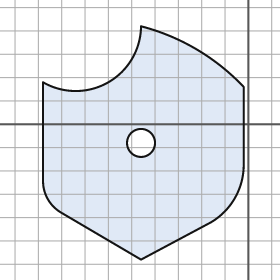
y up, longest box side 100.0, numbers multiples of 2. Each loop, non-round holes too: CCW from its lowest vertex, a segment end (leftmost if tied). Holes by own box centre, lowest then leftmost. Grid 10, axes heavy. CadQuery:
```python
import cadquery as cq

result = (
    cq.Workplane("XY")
    .moveTo(-46.0, -58.0)
    .lineTo(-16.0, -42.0)
    .threePointArc((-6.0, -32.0), (-2.0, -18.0))
    .lineTo(-2.0, 16.0)
    .threePointArc((-22.0, 32.0), (-46.0, 42.0))
    .threePointArc((-60.0, 18.0), (-88.0, 18.0))
    .lineTo(-88.0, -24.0)
    .threePointArc((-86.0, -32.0), (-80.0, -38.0))
    .close()
    .moveTo(-46.0, -8.0)
    .circle(6.0)
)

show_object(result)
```